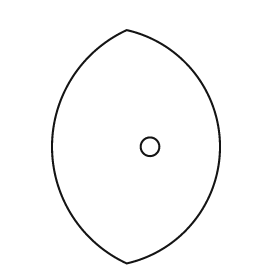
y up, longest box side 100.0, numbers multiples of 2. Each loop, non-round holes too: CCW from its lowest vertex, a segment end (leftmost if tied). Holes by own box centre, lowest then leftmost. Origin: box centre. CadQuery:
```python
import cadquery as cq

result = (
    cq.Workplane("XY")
    .moveTo(-4.0, -50.0)
    .threePointArc((36.0, 0.0), (-4.0, 50.0))
    .threePointArc((-36.0, 0.0), (-4.0, -50.0))
    .close()
    .moveTo(6.0, 0.0)
    .circle(4.0)
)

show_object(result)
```